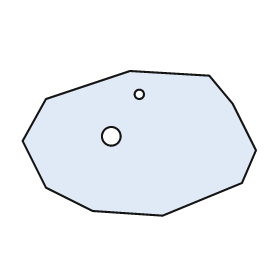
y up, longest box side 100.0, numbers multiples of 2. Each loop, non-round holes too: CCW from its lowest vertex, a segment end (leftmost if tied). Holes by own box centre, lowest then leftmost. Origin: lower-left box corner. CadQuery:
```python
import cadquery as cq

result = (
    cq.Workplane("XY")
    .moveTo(60.0, 0.0)
    .lineTo(94.0, 14.0)
    .lineTo(100.0, 28.0)
    .lineTo(90.0, 48.0)
    .lineTo(80.0, 60.0)
    .lineTo(46.0, 62.0)
    .lineTo(10.0, 50.0)
    .lineTo(0.0, 32.0)
    .lineTo(10.0, 12.0)
    .lineTo(30.0, 2.0)
    .close()
    .moveTo(38.0, 34.0)
    .circle(4.0)
    .moveTo(50.0, 52.0)
    .circle(2.0)
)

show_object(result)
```